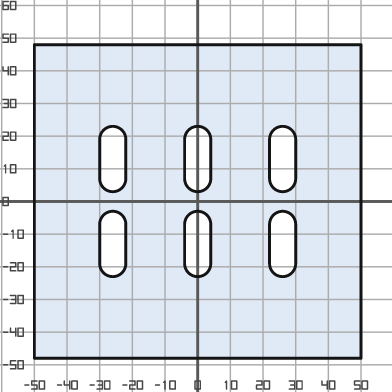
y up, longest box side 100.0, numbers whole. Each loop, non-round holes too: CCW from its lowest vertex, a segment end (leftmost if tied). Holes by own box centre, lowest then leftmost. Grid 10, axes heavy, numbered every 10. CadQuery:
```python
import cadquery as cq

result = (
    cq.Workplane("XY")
    .moveTo(-50.0, -48.0)
    .lineTo(50.0, -48.0)
    .lineTo(50.0, 48.0)
    .lineTo(-50.0, 48.0)
    .close()
    .moveTo(-30.0, -19.0)
    .threePointArc((-26.0, -23.0), (-22.0, -19.0))
    .lineTo(-22.0, -7.0)
    .threePointArc((-26.0, -3.0), (-30.0, -7.0))
    .close()
    .moveTo(-4.0, -19.0)
    .threePointArc((0.0, -23.0), (4.0, -19.0))
    .lineTo(4.0, -7.0)
    .threePointArc((0.0, -3.0), (-4.0, -7.0))
    .close()
    .moveTo(22.0, -19.0)
    .threePointArc((26.0, -23.0), (30.0, -19.0))
    .lineTo(30.0, -7.0)
    .threePointArc((26.0, -3.0), (22.0, -7.0))
    .close()
    .moveTo(-30.0, 7.0)
    .threePointArc((-26.0, 3.0), (-22.0, 7.0))
    .lineTo(-22.0, 19.0)
    .threePointArc((-26.0, 23.0), (-30.0, 19.0))
    .close()
    .moveTo(-4.0, 7.0)
    .threePointArc((0.0, 3.0), (4.0, 7.0))
    .lineTo(4.0, 19.0)
    .threePointArc((0.0, 23.0), (-4.0, 19.0))
    .close()
    .moveTo(22.0, 7.0)
    .threePointArc((26.0, 3.0), (30.0, 7.0))
    .lineTo(30.0, 19.0)
    .threePointArc((26.0, 23.0), (22.0, 19.0))
    .close()
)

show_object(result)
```